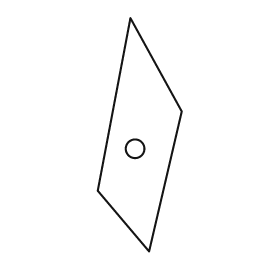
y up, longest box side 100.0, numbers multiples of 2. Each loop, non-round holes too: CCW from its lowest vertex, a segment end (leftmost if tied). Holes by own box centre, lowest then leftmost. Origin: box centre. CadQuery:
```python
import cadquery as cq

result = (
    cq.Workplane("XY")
    .moveTo(4.0, -50.0)
    .lineTo(18.0, 10.0)
    .lineTo(-4.0, 50.0)
    .lineTo(-18.0, -24.0)
    .close()
    .moveTo(-2.0, -6.0)
    .circle(4.0)
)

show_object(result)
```